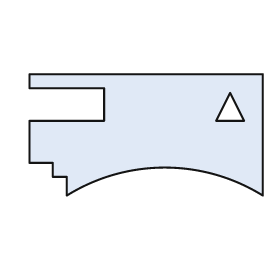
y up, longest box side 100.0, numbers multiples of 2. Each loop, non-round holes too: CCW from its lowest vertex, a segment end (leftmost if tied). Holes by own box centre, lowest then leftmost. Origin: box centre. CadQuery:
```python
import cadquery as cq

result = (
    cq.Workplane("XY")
    .moveTo(-34.0, -26.0)
    .threePointArc((8.0, -14.0), (50.0, -26.0))
    .lineTo(50.0, 26.0)
    .lineTo(-50.0, 26.0)
    .lineTo(-50.0, 20.0)
    .lineTo(-18.0, 20.0)
    .lineTo(-18.0, 6.0)
    .lineTo(-50.0, 6.0)
    .lineTo(-50.0, -12.0)
    .lineTo(-40.0, -12.0)
    .lineTo(-40.0, -18.0)
    .lineTo(-34.0, -18.0)
    .close()
    .moveTo(30.0, 6.0)
    .lineTo(42.0, 6.0)
    .lineTo(36.0, 18.0)
    .close()
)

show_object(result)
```